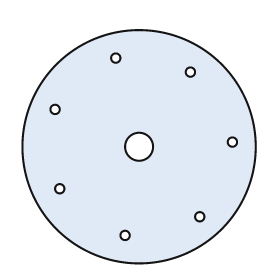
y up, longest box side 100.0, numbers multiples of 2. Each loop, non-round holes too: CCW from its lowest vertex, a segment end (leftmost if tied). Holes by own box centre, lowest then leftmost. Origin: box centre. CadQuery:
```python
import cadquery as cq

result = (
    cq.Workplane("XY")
    .moveTo(0.0, 0.0)
    .circle(50.0)
    .moveTo(-6.0, -38.0)
    .circle(2.0)
    .moveTo(26.0, -30.0)
    .circle(2.0)
    .moveTo(-34.0, -18.0)
    .circle(2.0)
    .moveTo(0.0, 0.0)
    .circle(6.0)
    .moveTo(40.0, 2.0)
    .circle(2.0)
    .moveTo(-36.0, 16.0)
    .circle(2.0)
    .moveTo(22.0, 32.0)
    .circle(2.0)
    .moveTo(-10.0, 38.0)
    .circle(2.0)
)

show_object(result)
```